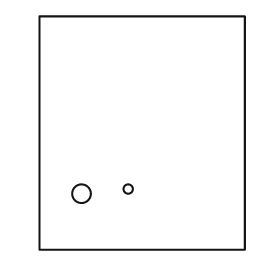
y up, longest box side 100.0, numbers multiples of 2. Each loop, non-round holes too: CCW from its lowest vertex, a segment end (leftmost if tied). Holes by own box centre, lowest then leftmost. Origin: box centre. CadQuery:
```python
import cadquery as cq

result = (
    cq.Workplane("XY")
    .moveTo(-44.0, -50.0)
    .lineTo(44.0, -50.0)
    .lineTo(44.0, 50.0)
    .lineTo(-44.0, 50.0)
    .close()
    .moveTo(-26.0, -26.0)
    .circle(4.0)
    .moveTo(-6.0, -24.0)
    .circle(2.0)
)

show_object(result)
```